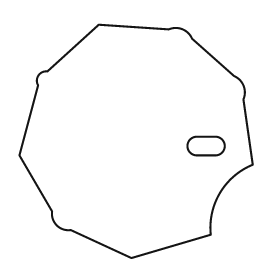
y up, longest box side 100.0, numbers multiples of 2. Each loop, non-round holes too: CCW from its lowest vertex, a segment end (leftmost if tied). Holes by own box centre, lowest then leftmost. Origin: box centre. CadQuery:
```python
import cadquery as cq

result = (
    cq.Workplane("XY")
    .moveTo(-2.0, -50.0)
    .lineTo(32.0, -40.0)
    .threePointArc((36.0, -22.0), (50.0, -10.0))
    .lineTo(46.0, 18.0)
    .threePointArc((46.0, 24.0), (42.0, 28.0))
    .lineTo(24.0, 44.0)
    .threePointArc((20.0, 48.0), (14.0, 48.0))
    .lineTo(-16.0, 50.0)
    .lineTo(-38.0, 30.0)
    .threePointArc((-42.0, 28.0), (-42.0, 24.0))
    .lineTo(-50.0, -6.0)
    .lineTo(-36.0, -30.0)
    .threePointArc((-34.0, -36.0), (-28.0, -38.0))
    .close()
    .moveTo(26.0, -6.0)
    .lineTo(34.0, -6.0)
    .threePointArc((38.0, -2.0), (34.0, 2.0))
    .lineTo(26.0, 2.0)
    .threePointArc((22.0, -2.0), (26.0, -6.0))
    .close()
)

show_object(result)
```